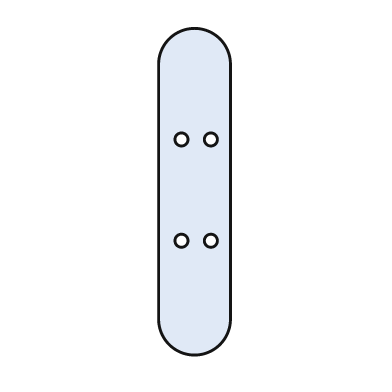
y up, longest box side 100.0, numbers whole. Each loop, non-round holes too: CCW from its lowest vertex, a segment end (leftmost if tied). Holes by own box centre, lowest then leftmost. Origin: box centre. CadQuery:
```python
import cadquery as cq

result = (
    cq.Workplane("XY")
    .moveTo(-11.0, -39.0)
    .threePointArc((0.0, -50.0), (11.0, -39.0))
    .lineTo(11.0, 39.0)
    .threePointArc((0.0, 50.0), (-11.0, 39.0))
    .close()
    .moveTo(-4.0, -15.0)
    .circle(2.0)
    .moveTo(5.0, -15.0)
    .circle(2.0)
    .moveTo(-4.0, 16.0)
    .circle(2.0)
    .moveTo(5.0, 16.0)
    .circle(2.0)
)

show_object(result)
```